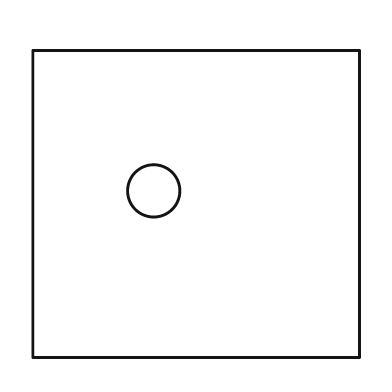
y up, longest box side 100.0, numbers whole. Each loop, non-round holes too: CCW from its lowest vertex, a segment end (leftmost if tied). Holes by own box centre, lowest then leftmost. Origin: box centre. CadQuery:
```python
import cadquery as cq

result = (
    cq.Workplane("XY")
    .moveTo(-50.0, -47.0)
    .lineTo(50.0, -47.0)
    .lineTo(50.0, 47.0)
    .lineTo(-50.0, 47.0)
    .close()
    .moveTo(-13.0, 4.0)
    .circle(8.0)
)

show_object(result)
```